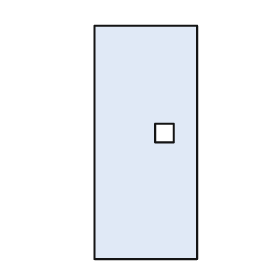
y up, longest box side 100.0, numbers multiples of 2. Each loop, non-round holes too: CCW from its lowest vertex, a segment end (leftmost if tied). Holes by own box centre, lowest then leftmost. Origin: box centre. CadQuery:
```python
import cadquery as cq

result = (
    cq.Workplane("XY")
    .moveTo(-22.0, -50.0)
    .lineTo(22.0, -50.0)
    .lineTo(22.0, 50.0)
    .lineTo(-22.0, 50.0)
    .close()
    .moveTo(4.0, 0.0)
    .lineTo(12.0, 0.0)
    .lineTo(12.0, 8.0)
    .lineTo(4.0, 8.0)
    .close()
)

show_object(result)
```